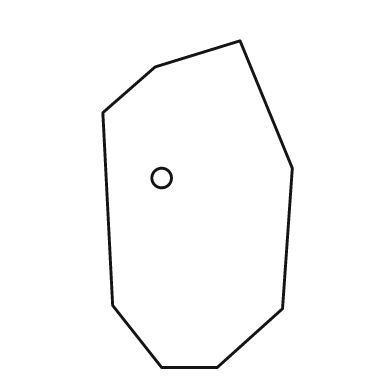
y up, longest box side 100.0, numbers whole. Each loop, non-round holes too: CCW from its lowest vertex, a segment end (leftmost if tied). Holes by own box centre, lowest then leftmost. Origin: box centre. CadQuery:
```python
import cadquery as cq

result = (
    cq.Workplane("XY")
    .moveTo(-11.0, -50.0)
    .lineTo(6.0, -50.0)
    .lineTo(26.0, -32.0)
    .lineTo(29.0, 11.0)
    .lineTo(13.0, 50.0)
    .lineTo(-13.0, 42.0)
    .lineTo(-29.0, 28.0)
    .lineTo(-26.0, -31.0)
    .close()
    .moveTo(-11.0, 8.0)
    .circle(3.0)
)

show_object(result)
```